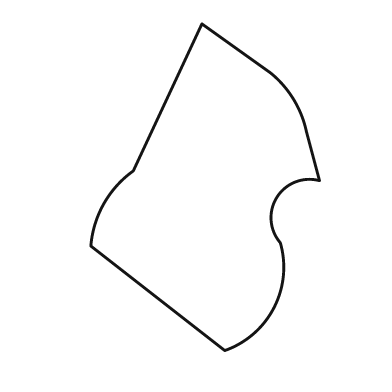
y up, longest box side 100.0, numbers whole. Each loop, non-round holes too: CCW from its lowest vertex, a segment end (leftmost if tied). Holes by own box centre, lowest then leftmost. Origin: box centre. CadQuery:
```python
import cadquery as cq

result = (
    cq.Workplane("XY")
    .moveTo(6.0, -50.0)
    .threePointArc((21.0, -37.0), (23.0, -17.0))
    .threePointArc((22.0, -3.0), (35.0, 2.0))
    .lineTo(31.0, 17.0)
    .threePointArc((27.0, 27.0), (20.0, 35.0))
    .lineTo(-1.0, 50.0)
    .lineTo(-22.0, 5.0)
    .threePointArc((-31.0, -5.0), (-35.0, -18.0))
    .close()
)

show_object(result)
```